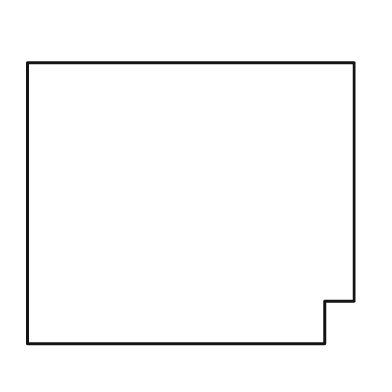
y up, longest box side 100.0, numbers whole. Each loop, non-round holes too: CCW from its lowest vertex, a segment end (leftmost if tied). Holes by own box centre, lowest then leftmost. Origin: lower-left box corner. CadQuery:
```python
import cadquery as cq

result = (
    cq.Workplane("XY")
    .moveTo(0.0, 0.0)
    .lineTo(91.0, 0.0)
    .lineTo(91.0, 13.0)
    .lineTo(100.0, 13.0)
    .lineTo(100.0, 86.0)
    .lineTo(0.0, 86.0)
    .close()
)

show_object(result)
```